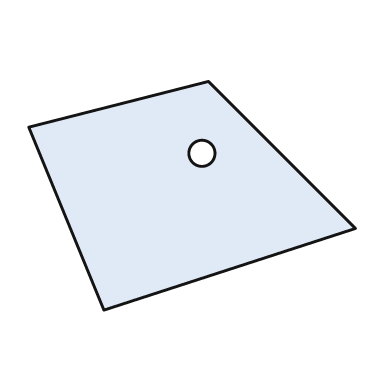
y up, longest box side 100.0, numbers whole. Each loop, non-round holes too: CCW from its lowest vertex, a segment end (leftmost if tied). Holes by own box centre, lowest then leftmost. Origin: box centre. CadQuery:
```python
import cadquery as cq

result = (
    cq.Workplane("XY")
    .moveTo(-27.0, -35.0)
    .lineTo(50.0, -10.0)
    .lineTo(5.0, 35.0)
    .lineTo(-50.0, 21.0)
    .close()
    .moveTo(3.0, 13.0)
    .circle(4.0)
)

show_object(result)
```